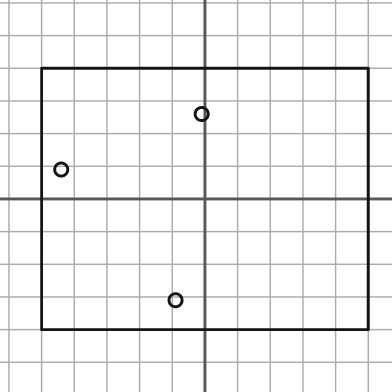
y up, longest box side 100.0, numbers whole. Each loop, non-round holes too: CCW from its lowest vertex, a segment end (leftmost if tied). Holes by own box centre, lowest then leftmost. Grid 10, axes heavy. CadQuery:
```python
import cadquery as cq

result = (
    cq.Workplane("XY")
    .moveTo(-50.0, -40.0)
    .lineTo(50.0, -40.0)
    .lineTo(50.0, 40.0)
    .lineTo(-50.0, 40.0)
    .close()
    .moveTo(-9.0, -31.0)
    .circle(2.0)
    .moveTo(-44.0, 9.0)
    .circle(2.0)
    .moveTo(-1.0, 26.0)
    .circle(2.0)
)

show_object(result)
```